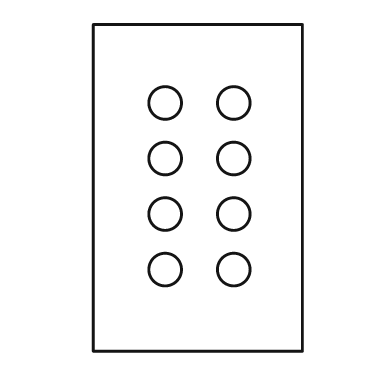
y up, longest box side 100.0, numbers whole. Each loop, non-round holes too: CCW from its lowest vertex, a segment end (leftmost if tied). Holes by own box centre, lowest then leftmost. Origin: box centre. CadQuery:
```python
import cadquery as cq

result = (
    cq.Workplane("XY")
    .moveTo(-32.0, -50.0)
    .lineTo(32.0, -50.0)
    .lineTo(32.0, 50.0)
    .lineTo(-32.0, 50.0)
    .close()
    .moveTo(-10.0, -25.0)
    .circle(5.0)
    .moveTo(11.0, -25.0)
    .circle(5.0)
    .moveTo(-10.0, -8.0)
    .circle(5.0)
    .moveTo(11.0, -8.0)
    .circle(5.0)
    .moveTo(-10.0, 9.0)
    .circle(5.0)
    .moveTo(11.0, 9.0)
    .circle(5.0)
    .moveTo(-10.0, 26.0)
    .circle(5.0)
    .moveTo(11.0, 26.0)
    .circle(5.0)
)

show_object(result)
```